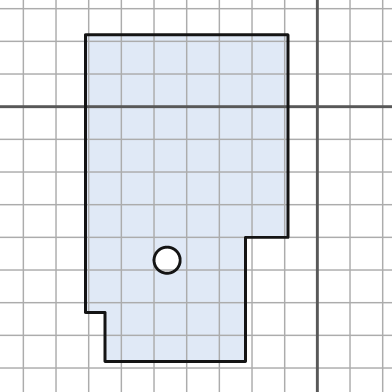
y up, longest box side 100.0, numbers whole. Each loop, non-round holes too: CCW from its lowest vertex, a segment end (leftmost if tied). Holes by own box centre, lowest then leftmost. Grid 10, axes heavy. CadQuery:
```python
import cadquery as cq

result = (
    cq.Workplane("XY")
    .moveTo(-65.0, -78.0)
    .lineTo(-22.0, -78.0)
    .lineTo(-22.0, -40.0)
    .lineTo(-9.0, -40.0)
    .lineTo(-9.0, 22.0)
    .lineTo(-71.0, 22.0)
    .lineTo(-71.0, -63.0)
    .lineTo(-65.0, -63.0)
    .close()
    .moveTo(-46.0, -47.0)
    .circle(4.0)
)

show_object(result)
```